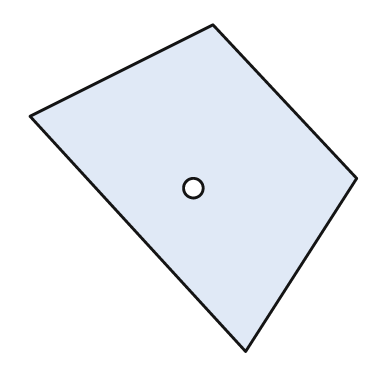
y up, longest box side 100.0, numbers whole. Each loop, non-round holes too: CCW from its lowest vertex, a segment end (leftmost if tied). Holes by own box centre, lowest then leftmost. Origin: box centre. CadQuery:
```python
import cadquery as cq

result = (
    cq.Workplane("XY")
    .moveTo(16.0, -50.0)
    .lineTo(50.0, 3.0)
    .lineTo(6.0, 50.0)
    .lineTo(-50.0, 22.0)
    .close()
    .moveTo(0.0, 0.0)
    .circle(3.0)
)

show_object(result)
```